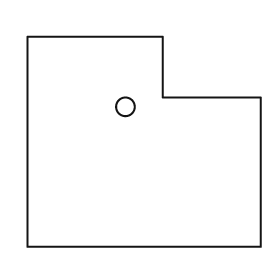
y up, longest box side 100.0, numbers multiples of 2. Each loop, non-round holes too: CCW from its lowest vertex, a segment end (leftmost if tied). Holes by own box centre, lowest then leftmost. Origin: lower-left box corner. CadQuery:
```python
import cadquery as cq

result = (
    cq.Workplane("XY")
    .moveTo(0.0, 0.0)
    .lineTo(100.0, 0.0)
    .lineTo(100.0, 64.0)
    .lineTo(58.0, 64.0)
    .lineTo(58.0, 90.0)
    .lineTo(0.0, 90.0)
    .close()
    .moveTo(42.0, 60.0)
    .circle(4.0)
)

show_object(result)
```